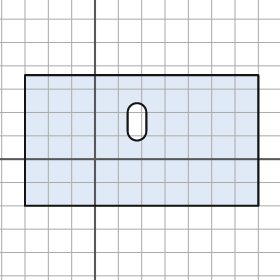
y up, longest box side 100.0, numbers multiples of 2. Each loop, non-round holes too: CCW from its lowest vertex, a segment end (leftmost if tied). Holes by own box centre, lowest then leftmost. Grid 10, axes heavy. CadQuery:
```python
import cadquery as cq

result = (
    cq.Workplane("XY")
    .moveTo(-30.0, -20.0)
    .lineTo(70.0, -20.0)
    .lineTo(70.0, 36.0)
    .lineTo(-30.0, 36.0)
    .close()
    .moveTo(14.0, 12.0)
    .threePointArc((18.0, 8.0), (22.0, 12.0))
    .lineTo(22.0, 20.0)
    .threePointArc((18.0, 24.0), (14.0, 20.0))
    .close()
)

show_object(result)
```